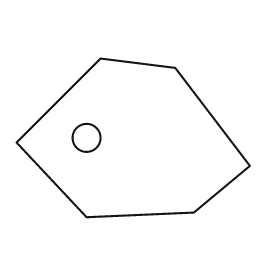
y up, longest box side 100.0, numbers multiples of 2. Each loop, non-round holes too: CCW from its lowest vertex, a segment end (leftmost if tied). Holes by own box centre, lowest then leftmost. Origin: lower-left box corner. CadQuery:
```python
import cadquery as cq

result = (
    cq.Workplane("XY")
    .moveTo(30.0, 0.0)
    .lineTo(76.0, 2.0)
    .lineTo(100.0, 22.0)
    .lineTo(68.0, 64.0)
    .lineTo(36.0, 68.0)
    .lineTo(0.0, 32.0)
    .close()
    .moveTo(30.0, 34.0)
    .circle(6.0)
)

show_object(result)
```